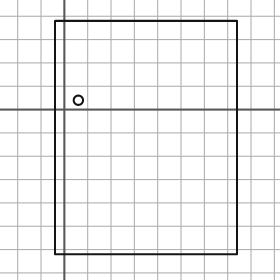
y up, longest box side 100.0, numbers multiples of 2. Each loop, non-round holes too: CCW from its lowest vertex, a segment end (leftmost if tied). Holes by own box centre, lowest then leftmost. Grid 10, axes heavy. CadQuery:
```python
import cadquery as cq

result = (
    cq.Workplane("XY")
    .moveTo(-4.0, -62.0)
    .lineTo(74.0, -62.0)
    .lineTo(74.0, 38.0)
    .lineTo(-4.0, 38.0)
    .close()
    .moveTo(6.0, 4.0)
    .circle(2.0)
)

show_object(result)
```